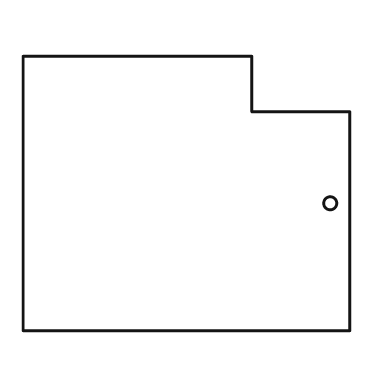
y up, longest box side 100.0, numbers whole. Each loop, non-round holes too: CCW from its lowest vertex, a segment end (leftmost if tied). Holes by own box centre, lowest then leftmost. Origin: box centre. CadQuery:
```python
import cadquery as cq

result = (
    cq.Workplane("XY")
    .moveTo(-50.0, -42.0)
    .lineTo(50.0, -42.0)
    .lineTo(50.0, 25.0)
    .lineTo(20.0, 25.0)
    .lineTo(20.0, 42.0)
    .lineTo(-50.0, 42.0)
    .close()
    .moveTo(44.0, -3.0)
    .circle(2.0)
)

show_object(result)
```